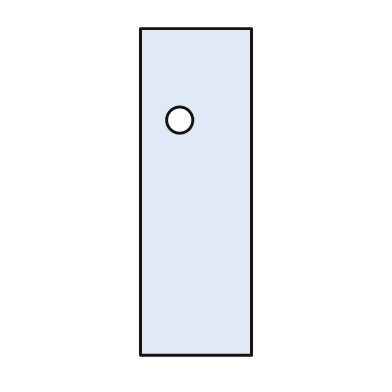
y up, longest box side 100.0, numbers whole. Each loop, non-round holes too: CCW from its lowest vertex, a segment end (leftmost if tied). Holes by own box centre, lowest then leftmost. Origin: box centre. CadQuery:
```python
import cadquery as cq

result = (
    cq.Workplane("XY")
    .moveTo(-17.0, -50.0)
    .lineTo(17.0, -50.0)
    .lineTo(17.0, 50.0)
    .lineTo(-17.0, 50.0)
    .close()
    .moveTo(-5.0, 22.0)
    .circle(4.0)
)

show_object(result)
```